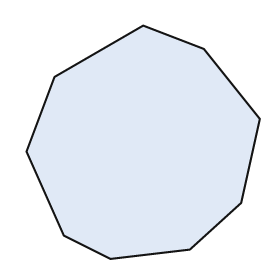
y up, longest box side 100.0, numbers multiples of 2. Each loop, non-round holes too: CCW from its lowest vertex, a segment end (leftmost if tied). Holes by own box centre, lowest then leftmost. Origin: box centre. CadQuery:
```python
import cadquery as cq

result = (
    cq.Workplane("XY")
    .moveTo(-14.0, -50.0)
    .lineTo(20.0, -46.0)
    .lineTo(42.0, -26.0)
    .lineTo(50.0, 10.0)
    .lineTo(26.0, 40.0)
    .lineTo(0.0, 50.0)
    .lineTo(-38.0, 28.0)
    .lineTo(-50.0, -4.0)
    .lineTo(-34.0, -40.0)
    .close()
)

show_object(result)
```